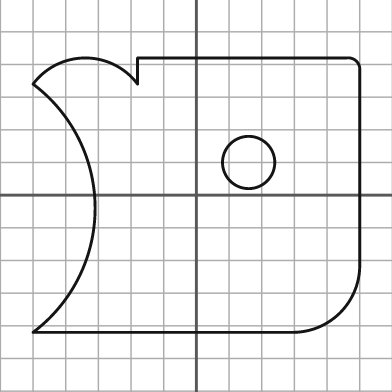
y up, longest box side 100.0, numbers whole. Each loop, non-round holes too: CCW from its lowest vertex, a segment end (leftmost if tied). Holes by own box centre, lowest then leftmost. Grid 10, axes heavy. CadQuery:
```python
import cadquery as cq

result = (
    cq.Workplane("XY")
    .moveTo(-50.0, -42.0)
    .lineTo(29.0, -42.0)
    .threePointArc((44.0, -36.0), (50.0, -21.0))
    .lineTo(50.0, 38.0)
    .threePointArc((49.0, 41.0), (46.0, 42.0))
    .lineTo(-18.0, 42.0)
    .lineTo(-18.0, 34.0)
    .threePointArc((-34.0, 42.0), (-50.0, 34.0))
    .threePointArc((-31.0, -4.0), (-50.0, -42.0))
    .close()
    .moveTo(16.0, 10.0)
    .circle(8.0)
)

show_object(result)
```